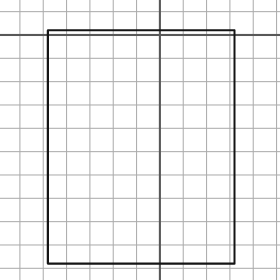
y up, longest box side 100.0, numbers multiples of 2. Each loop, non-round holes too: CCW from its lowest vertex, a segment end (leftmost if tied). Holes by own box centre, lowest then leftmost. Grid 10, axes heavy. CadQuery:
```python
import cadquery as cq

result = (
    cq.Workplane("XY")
    .moveTo(-48.0, -98.0)
    .lineTo(32.0, -98.0)
    .lineTo(32.0, 2.0)
    .lineTo(-48.0, 2.0)
    .close()
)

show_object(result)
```